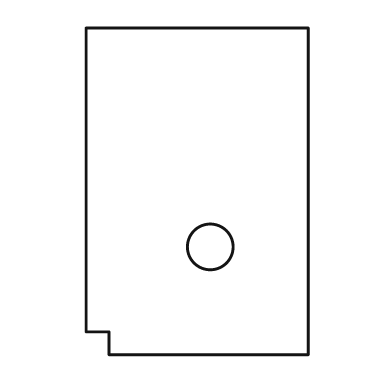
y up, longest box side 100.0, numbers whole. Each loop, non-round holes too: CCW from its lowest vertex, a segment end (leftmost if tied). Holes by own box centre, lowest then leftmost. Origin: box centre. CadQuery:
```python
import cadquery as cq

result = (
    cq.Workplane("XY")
    .moveTo(-27.0, -50.0)
    .lineTo(34.0, -50.0)
    .lineTo(34.0, 50.0)
    .lineTo(-34.0, 50.0)
    .lineTo(-34.0, -43.0)
    .lineTo(-27.0, -43.0)
    .close()
    .moveTo(4.0, -17.0)
    .circle(7.0)
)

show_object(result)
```